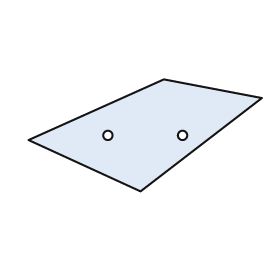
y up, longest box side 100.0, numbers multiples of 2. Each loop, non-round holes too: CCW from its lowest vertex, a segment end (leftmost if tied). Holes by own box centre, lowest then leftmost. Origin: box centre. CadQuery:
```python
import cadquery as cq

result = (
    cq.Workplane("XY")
    .moveTo(-2.0, -24.0)
    .lineTo(50.0, 16.0)
    .lineTo(8.0, 24.0)
    .lineTo(-50.0, -2.0)
    .close()
    .moveTo(-16.0, 0.0)
    .circle(2.0)
    .moveTo(16.0, 0.0)
    .circle(2.0)
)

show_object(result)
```